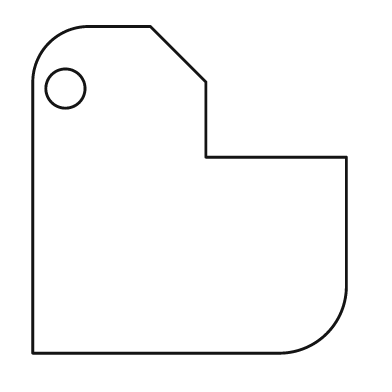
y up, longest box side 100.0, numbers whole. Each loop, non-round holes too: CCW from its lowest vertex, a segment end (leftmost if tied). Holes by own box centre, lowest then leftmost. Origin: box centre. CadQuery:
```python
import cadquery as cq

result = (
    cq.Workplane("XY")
    .moveTo(-48.0, -50.0)
    .lineTo(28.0, -50.0)
    .threePointArc((42.0, -44.0), (48.0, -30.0))
    .lineTo(48.0, 10.0)
    .lineTo(5.0, 10.0)
    .lineTo(5.0, 33.0)
    .lineTo(-12.0, 50.0)
    .lineTo(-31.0, 50.0)
    .threePointArc((-43.0, 45.0), (-48.0, 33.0))
    .close()
    .moveTo(-38.0, 31.0)
    .circle(6.0)
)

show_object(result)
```